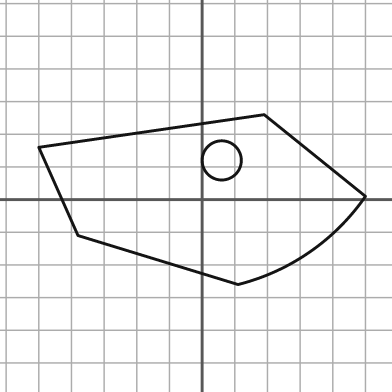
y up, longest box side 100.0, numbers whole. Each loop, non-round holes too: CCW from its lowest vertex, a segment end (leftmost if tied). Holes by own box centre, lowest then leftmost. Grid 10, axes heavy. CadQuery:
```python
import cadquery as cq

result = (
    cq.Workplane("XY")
    .moveTo(11.0, -26.0)
    .threePointArc((33.0, -16.0), (50.0, 1.0))
    .lineTo(19.0, 26.0)
    .lineTo(-50.0, 16.0)
    .lineTo(-38.0, -11.0)
    .close()
    .moveTo(6.0, 12.0)
    .circle(6.0)
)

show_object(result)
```